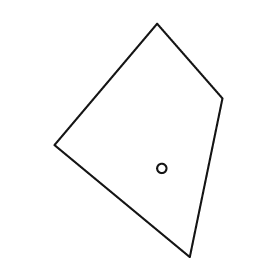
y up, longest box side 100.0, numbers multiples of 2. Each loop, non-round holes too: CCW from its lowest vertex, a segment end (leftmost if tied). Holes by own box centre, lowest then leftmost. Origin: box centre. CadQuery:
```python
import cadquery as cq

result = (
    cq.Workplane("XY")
    .moveTo(22.0, -50.0)
    .lineTo(36.0, 18.0)
    .lineTo(8.0, 50.0)
    .lineTo(-36.0, -2.0)
    .close()
    .moveTo(10.0, -12.0)
    .circle(2.0)
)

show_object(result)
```